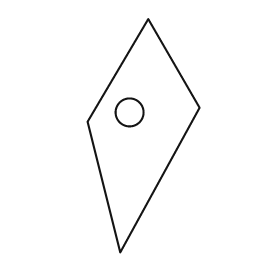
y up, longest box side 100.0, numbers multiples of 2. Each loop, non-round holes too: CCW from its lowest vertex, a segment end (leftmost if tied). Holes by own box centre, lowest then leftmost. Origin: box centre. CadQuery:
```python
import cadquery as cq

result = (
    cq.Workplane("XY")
    .moveTo(-10.0, -50.0)
    .lineTo(24.0, 12.0)
    .lineTo(2.0, 50.0)
    .lineTo(-24.0, 6.0)
    .close()
    .moveTo(-6.0, 10.0)
    .circle(6.0)
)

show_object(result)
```